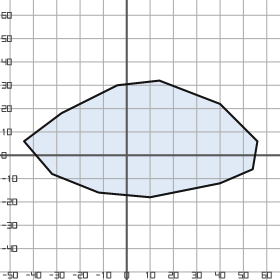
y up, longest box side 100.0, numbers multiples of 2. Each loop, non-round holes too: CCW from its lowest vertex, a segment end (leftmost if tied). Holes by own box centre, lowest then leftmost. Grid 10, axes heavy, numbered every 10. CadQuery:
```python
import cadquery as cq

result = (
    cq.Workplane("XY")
    .moveTo(10.0, -18.0)
    .lineTo(40.0, -12.0)
    .lineTo(54.0, -6.0)
    .lineTo(56.0, 6.0)
    .lineTo(40.0, 22.0)
    .lineTo(14.0, 32.0)
    .lineTo(-4.0, 30.0)
    .lineTo(-28.0, 18.0)
    .lineTo(-44.0, 6.0)
    .lineTo(-32.0, -8.0)
    .lineTo(-12.0, -16.0)
    .close()
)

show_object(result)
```